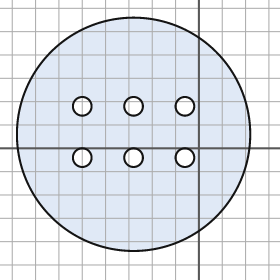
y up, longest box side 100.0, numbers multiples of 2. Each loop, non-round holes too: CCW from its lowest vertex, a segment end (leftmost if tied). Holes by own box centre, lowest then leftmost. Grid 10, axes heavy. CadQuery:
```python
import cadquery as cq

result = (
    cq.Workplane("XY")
    .moveTo(-28.0, 6.0)
    .circle(50.0)
    .moveTo(-50.0, -4.0)
    .circle(4.0)
    .moveTo(-28.0, -4.0)
    .circle(4.0)
    .moveTo(-6.0, -4.0)
    .circle(4.0)
    .moveTo(-50.0, 18.0)
    .circle(4.0)
    .moveTo(-28.0, 18.0)
    .circle(4.0)
    .moveTo(-6.0, 18.0)
    .circle(4.0)
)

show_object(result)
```